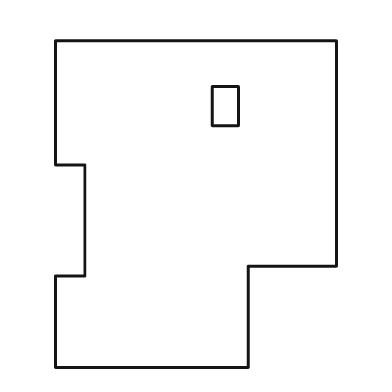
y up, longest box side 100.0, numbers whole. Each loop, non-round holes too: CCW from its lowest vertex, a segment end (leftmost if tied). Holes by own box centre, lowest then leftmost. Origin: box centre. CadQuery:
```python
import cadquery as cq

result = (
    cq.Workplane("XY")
    .moveTo(-43.0, -50.0)
    .lineTo(16.0, -50.0)
    .lineTo(16.0, -19.0)
    .lineTo(43.0, -19.0)
    .lineTo(43.0, 50.0)
    .lineTo(-43.0, 50.0)
    .lineTo(-43.0, 12.0)
    .lineTo(-34.0, 12.0)
    .lineTo(-34.0, -22.0)
    .lineTo(-43.0, -22.0)
    .close()
    .moveTo(5.0, 24.0)
    .lineTo(13.0, 24.0)
    .lineTo(13.0, 36.0)
    .lineTo(5.0, 36.0)
    .close()
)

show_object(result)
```